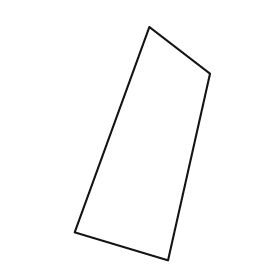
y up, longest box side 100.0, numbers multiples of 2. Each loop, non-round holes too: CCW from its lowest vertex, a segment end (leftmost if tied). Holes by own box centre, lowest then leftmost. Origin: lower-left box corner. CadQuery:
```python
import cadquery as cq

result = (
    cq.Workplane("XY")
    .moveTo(40.0, 0.0)
    .lineTo(58.0, 80.0)
    .lineTo(32.0, 100.0)
    .lineTo(0.0, 12.0)
    .close()
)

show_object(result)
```